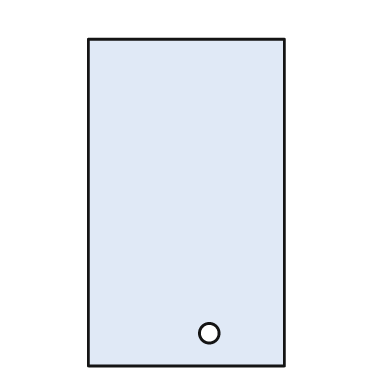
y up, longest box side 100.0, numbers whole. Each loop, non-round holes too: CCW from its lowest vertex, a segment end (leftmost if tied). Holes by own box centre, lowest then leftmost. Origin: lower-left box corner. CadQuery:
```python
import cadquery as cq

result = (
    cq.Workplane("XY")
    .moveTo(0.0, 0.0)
    .lineTo(60.0, 0.0)
    .lineTo(60.0, 100.0)
    .lineTo(0.0, 100.0)
    .close()
    .moveTo(37.0, 10.0)
    .circle(3.0)
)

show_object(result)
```